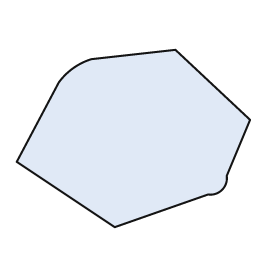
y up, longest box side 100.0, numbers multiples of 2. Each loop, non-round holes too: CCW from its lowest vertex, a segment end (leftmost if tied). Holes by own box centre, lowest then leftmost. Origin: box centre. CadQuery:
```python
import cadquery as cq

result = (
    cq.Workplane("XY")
    .moveTo(-8.0, -38.0)
    .lineTo(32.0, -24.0)
    .threePointArc((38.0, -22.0), (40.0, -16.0))
    .lineTo(50.0, 8.0)
    .lineTo(18.0, 38.0)
    .lineTo(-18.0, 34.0)
    .threePointArc((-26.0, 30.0), (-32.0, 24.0))
    .lineTo(-50.0, -10.0)
    .close()
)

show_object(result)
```